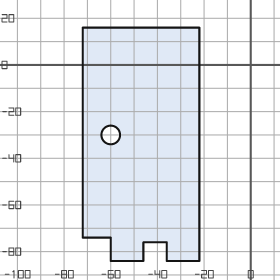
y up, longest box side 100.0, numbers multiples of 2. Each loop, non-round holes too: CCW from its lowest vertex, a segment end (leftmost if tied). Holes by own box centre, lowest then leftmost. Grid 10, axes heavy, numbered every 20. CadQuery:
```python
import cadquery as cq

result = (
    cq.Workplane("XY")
    .moveTo(-60.0, -84.0)
    .lineTo(-46.0, -84.0)
    .lineTo(-46.0, -76.0)
    .lineTo(-36.0, -76.0)
    .lineTo(-36.0, -84.0)
    .lineTo(-22.0, -84.0)
    .lineTo(-22.0, 16.0)
    .lineTo(-72.0, 16.0)
    .lineTo(-72.0, -74.0)
    .lineTo(-60.0, -74.0)
    .close()
    .moveTo(-60.0, -30.0)
    .circle(4.0)
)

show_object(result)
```